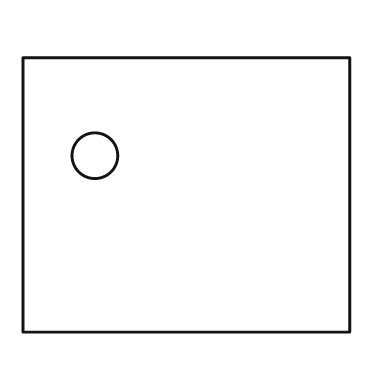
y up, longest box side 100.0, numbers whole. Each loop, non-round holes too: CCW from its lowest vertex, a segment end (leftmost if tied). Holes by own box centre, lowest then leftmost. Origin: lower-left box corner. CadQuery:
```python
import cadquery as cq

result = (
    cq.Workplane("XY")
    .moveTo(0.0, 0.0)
    .lineTo(100.0, 0.0)
    .lineTo(100.0, 84.0)
    .lineTo(0.0, 84.0)
    .close()
    .moveTo(22.0, 54.0)
    .circle(7.0)
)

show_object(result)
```